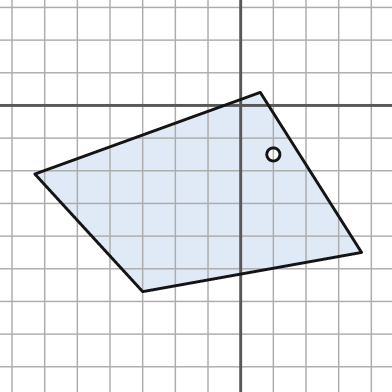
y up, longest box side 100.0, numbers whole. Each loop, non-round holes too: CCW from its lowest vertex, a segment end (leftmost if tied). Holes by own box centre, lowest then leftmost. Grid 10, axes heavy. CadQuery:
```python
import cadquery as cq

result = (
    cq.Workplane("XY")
    .moveTo(-30.0, -57.0)
    .lineTo(37.0, -45.0)
    .lineTo(6.0, 4.0)
    .lineTo(-63.0, -21.0)
    .close()
    .moveTo(10.0, -15.0)
    .circle(2.0)
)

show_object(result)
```